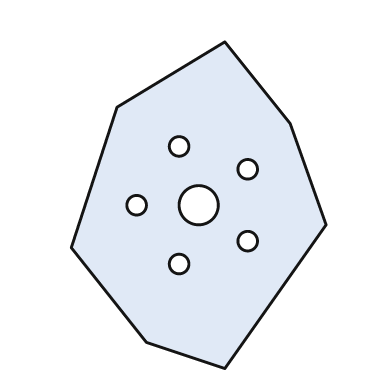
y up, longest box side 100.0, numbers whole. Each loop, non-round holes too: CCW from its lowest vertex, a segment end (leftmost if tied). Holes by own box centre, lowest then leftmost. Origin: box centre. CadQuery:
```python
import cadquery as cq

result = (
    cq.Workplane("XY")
    .moveTo(8.0, -50.0)
    .lineTo(39.0, -6.0)
    .lineTo(28.0, 25.0)
    .lineTo(8.0, 50.0)
    .lineTo(-25.0, 30.0)
    .lineTo(-39.0, -13.0)
    .lineTo(-16.0, -42.0)
    .close()
    .moveTo(-6.0, -18.0)
    .circle(3.0)
    .moveTo(15.0, -11.0)
    .circle(3.0)
    .moveTo(-19.0, 0.0)
    .circle(3.0)
    .moveTo(0.0, 0.0)
    .circle(6.0)
    .moveTo(15.0, 11.0)
    .circle(3.0)
    .moveTo(-6.0, 18.0)
    .circle(3.0)
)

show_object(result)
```